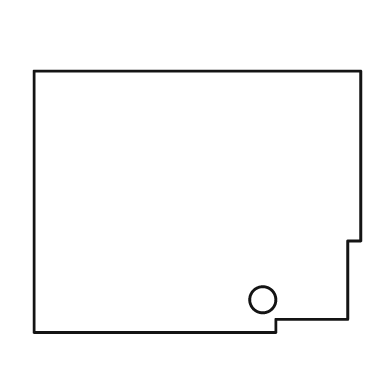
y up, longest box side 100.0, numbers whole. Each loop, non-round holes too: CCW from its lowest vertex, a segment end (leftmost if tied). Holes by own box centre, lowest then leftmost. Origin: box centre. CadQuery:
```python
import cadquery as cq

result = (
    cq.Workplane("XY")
    .moveTo(-50.0, -40.0)
    .lineTo(24.0, -40.0)
    .lineTo(24.0, -36.0)
    .lineTo(46.0, -36.0)
    .lineTo(46.0, -12.0)
    .lineTo(50.0, -12.0)
    .lineTo(50.0, 40.0)
    .lineTo(-50.0, 40.0)
    .close()
    .moveTo(20.0, -30.0)
    .circle(4.0)
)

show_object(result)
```